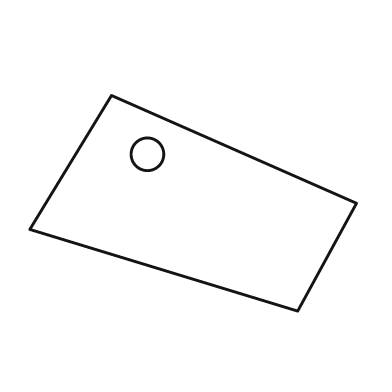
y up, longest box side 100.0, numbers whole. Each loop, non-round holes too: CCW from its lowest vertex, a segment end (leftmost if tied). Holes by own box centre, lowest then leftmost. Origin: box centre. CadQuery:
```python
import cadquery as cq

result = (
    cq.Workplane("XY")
    .moveTo(32.0, -33.0)
    .lineTo(50.0, 0.0)
    .lineTo(-25.0, 33.0)
    .lineTo(-50.0, -8.0)
    .close()
    .moveTo(-14.0, 15.0)
    .circle(5.0)
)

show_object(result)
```